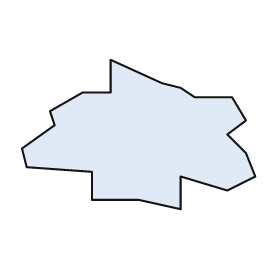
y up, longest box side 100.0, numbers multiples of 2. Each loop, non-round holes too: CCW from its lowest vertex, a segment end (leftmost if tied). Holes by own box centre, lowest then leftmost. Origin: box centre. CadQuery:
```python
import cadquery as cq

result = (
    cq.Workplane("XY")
    .moveTo(18.0, -32.0)
    .lineTo(18.0, -18.0)
    .lineTo(38.0, -24.0)
    .lineTo(50.0, -18.0)
    .lineTo(46.0, -8.0)
    .lineTo(38.0, 0.0)
    .lineTo(46.0, 6.0)
    .lineTo(40.0, 16.0)
    .lineTo(24.0, 16.0)
    .lineTo(18.0, 20.0)
    .lineTo(10.0, 22.0)
    .lineTo(-12.0, 32.0)
    .lineTo(-12.0, 18.0)
    .lineTo(-24.0, 18.0)
    .lineTo(-38.0, 10.0)
    .lineTo(-36.0, 4.0)
    .lineTo(-50.0, -6.0)
    .lineTo(-48.0, -14.0)
    .lineTo(-20.0, -16.0)
    .lineTo(-20.0, -28.0)
    .lineTo(0.0, -28.0)
    .close()
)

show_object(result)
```